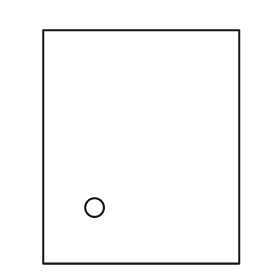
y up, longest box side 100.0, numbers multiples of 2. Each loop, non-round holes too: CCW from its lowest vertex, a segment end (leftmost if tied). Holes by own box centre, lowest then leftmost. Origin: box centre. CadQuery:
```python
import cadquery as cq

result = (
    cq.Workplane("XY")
    .moveTo(-42.0, -50.0)
    .lineTo(42.0, -50.0)
    .lineTo(42.0, 50.0)
    .lineTo(-42.0, 50.0)
    .close()
    .moveTo(-20.0, -26.0)
    .circle(4.0)
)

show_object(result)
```